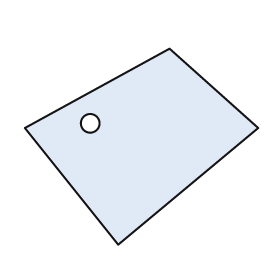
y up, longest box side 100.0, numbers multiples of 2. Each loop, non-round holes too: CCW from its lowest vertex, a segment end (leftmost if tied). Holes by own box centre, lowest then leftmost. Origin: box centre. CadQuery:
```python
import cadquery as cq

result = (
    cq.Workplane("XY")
    .moveTo(-10.0, -42.0)
    .lineTo(50.0, 8.0)
    .lineTo(12.0, 42.0)
    .lineTo(-50.0, 8.0)
    .close()
    .moveTo(-22.0, 10.0)
    .circle(4.0)
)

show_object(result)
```